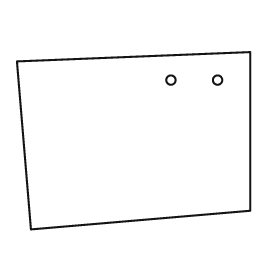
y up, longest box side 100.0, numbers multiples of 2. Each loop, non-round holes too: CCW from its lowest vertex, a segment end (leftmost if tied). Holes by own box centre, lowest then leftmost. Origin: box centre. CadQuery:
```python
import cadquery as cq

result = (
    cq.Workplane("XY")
    .moveTo(-44.0, -38.0)
    .lineTo(50.0, -30.0)
    .lineTo(50.0, 38.0)
    .lineTo(-50.0, 34.0)
    .close()
    .moveTo(16.0, 26.0)
    .circle(2.0)
    .moveTo(36.0, 26.0)
    .circle(2.0)
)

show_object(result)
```